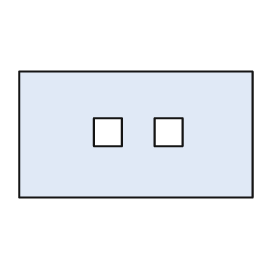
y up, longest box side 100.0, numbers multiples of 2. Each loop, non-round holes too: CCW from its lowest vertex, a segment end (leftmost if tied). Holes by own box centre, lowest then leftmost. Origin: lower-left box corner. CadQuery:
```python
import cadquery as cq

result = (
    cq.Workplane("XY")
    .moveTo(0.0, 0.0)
    .lineTo(100.0, 0.0)
    .lineTo(100.0, 54.0)
    .lineTo(0.0, 54.0)
    .close()
    .moveTo(32.0, 22.0)
    .lineTo(44.0, 22.0)
    .lineTo(44.0, 34.0)
    .lineTo(32.0, 34.0)
    .close()
    .moveTo(58.0, 22.0)
    .lineTo(70.0, 22.0)
    .lineTo(70.0, 34.0)
    .lineTo(58.0, 34.0)
    .close()
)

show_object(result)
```